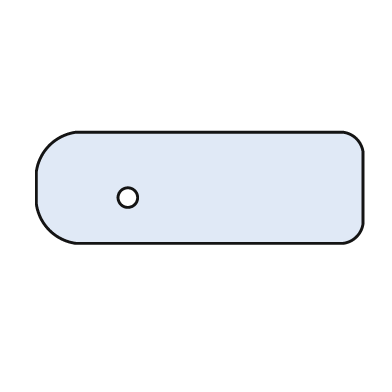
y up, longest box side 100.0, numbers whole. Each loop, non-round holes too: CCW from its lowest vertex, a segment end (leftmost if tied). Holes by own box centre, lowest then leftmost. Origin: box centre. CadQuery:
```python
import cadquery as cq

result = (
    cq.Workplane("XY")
    .moveTo(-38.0, -17.0)
    .lineTo(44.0, -17.0)
    .threePointArc((48.0, -15.0), (50.0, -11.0))
    .lineTo(50.0, 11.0)
    .threePointArc((48.0, 15.0), (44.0, 17.0))
    .lineTo(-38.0, 17.0)
    .threePointArc((-46.0, 13.0), (-50.0, 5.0))
    .lineTo(-50.0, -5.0)
    .threePointArc((-46.0, -13.0), (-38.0, -17.0))
    .close()
    .moveTo(-22.0, -3.0)
    .circle(3.0)
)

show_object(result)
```